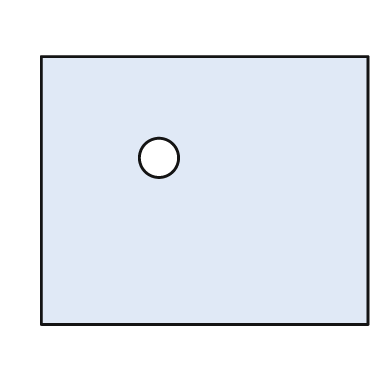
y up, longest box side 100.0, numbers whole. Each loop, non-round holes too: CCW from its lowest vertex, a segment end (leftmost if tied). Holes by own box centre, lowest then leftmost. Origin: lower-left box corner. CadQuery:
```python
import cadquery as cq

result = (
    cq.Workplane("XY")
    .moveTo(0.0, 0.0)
    .lineTo(100.0, 0.0)
    .lineTo(100.0, 82.0)
    .lineTo(0.0, 82.0)
    .close()
    .moveTo(36.0, 51.0)
    .circle(6.0)
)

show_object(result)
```